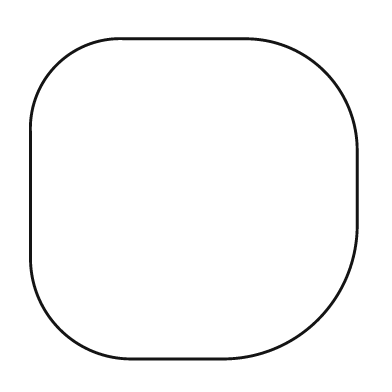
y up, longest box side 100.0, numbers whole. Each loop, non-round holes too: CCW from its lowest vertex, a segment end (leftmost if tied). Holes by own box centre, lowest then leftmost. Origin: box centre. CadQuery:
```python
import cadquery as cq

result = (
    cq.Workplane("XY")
    .moveTo(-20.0, -49.0)
    .lineTo(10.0, -49.0)
    .threePointArc((38.0, -37.0), (50.0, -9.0))
    .lineTo(50.0, 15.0)
    .threePointArc((40.0, 39.0), (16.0, 49.0))
    .lineTo(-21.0, 49.0)
    .threePointArc((-42.0, 41.0), (-50.0, 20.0))
    .lineTo(-50.0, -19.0)
    .threePointArc((-41.0, -40.0), (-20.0, -49.0))
    .close()
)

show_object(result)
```